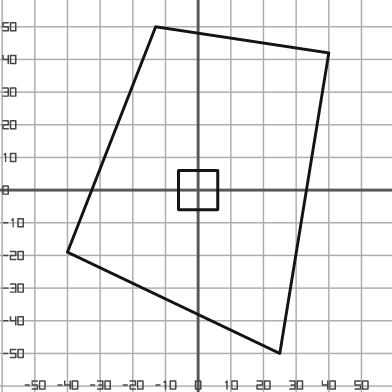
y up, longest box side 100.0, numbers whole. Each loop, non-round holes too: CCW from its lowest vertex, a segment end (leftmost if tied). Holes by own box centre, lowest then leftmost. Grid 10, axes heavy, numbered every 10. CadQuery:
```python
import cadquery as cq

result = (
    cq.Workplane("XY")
    .moveTo(25.0, -50.0)
    .lineTo(40.0, 42.0)
    .lineTo(-13.0, 50.0)
    .lineTo(-40.0, -19.0)
    .close()
    .moveTo(-6.0, -6.0)
    .lineTo(6.0, -6.0)
    .lineTo(6.0, 6.0)
    .lineTo(-6.0, 6.0)
    .close()
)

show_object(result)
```